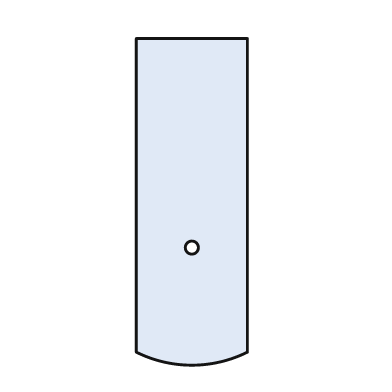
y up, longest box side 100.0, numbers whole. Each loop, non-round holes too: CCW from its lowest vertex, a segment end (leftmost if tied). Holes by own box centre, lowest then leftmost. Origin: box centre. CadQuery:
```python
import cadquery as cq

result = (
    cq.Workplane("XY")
    .moveTo(-17.0, -46.0)
    .threePointArc((0.0, -50.0), (17.0, -46.0))
    .lineTo(17.0, 50.0)
    .lineTo(-17.0, 50.0)
    .close()
    .moveTo(0.0, -14.0)
    .circle(2.0)
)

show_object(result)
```